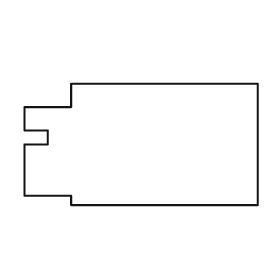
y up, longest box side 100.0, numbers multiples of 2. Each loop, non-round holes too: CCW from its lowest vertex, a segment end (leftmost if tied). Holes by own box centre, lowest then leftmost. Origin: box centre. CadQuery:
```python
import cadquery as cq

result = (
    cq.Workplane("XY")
    .moveTo(-30.0, -26.0)
    .lineTo(50.0, -26.0)
    .lineTo(50.0, 26.0)
    .lineTo(-30.0, 26.0)
    .lineTo(-30.0, 16.0)
    .lineTo(-50.0, 16.0)
    .lineTo(-50.0, 6.0)
    .lineTo(-40.0, 6.0)
    .lineTo(-40.0, 0.0)
    .lineTo(-50.0, 0.0)
    .lineTo(-50.0, -22.0)
    .lineTo(-30.0, -22.0)
    .close()
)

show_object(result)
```